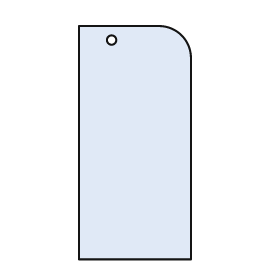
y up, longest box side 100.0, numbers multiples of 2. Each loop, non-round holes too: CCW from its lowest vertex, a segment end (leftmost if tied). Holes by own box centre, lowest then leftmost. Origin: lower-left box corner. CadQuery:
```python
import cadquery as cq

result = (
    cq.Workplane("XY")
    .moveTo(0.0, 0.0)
    .lineTo(48.0, 0.0)
    .lineTo(48.0, 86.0)
    .threePointArc((44.0, 96.0), (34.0, 100.0))
    .lineTo(0.0, 100.0)
    .close()
    .moveTo(14.0, 94.0)
    .circle(2.0)
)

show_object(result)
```